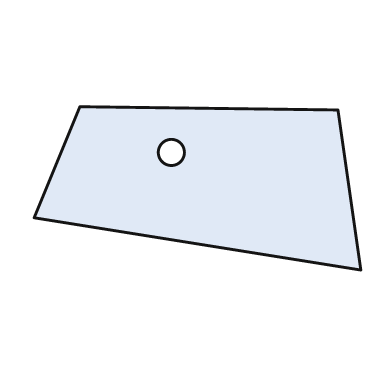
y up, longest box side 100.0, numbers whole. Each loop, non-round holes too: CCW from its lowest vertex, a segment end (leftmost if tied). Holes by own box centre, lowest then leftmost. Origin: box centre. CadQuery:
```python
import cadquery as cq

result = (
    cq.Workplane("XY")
    .moveTo(50.0, -25.0)
    .lineTo(43.0, 24.0)
    .lineTo(-36.0, 25.0)
    .lineTo(-50.0, -9.0)
    .close()
    .moveTo(-8.0, 11.0)
    .circle(4.0)
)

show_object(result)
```